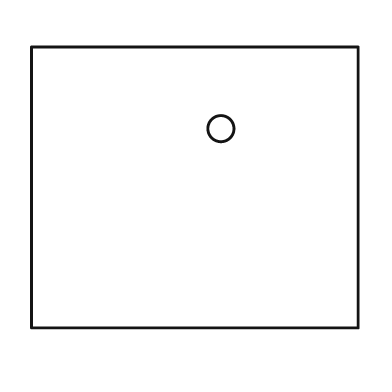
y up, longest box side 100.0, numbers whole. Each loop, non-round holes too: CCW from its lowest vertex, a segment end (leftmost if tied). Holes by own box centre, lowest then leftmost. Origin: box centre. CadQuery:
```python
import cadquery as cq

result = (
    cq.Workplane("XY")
    .moveTo(-50.0, -43.0)
    .lineTo(50.0, -43.0)
    .lineTo(50.0, 43.0)
    .lineTo(-50.0, 43.0)
    .close()
    .moveTo(8.0, 18.0)
    .circle(4.0)
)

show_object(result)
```